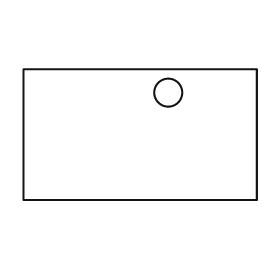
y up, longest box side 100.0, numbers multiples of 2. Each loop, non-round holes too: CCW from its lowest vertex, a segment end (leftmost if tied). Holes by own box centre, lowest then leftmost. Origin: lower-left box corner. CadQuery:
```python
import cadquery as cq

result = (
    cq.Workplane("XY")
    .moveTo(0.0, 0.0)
    .lineTo(100.0, 0.0)
    .lineTo(100.0, 56.0)
    .lineTo(0.0, 56.0)
    .close()
    .moveTo(62.0, 46.0)
    .circle(6.0)
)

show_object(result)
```